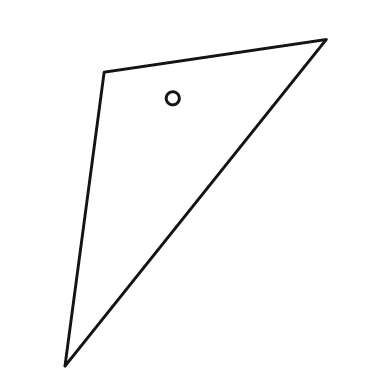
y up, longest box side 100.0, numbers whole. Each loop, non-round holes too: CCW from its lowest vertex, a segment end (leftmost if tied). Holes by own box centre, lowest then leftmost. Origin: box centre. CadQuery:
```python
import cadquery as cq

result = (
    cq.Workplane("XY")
    .moveTo(-40.0, -50.0)
    .lineTo(40.0, 50.0)
    .lineTo(-28.0, 40.0)
    .close()
    .moveTo(-7.0, 32.0)
    .circle(2.0)
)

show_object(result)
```